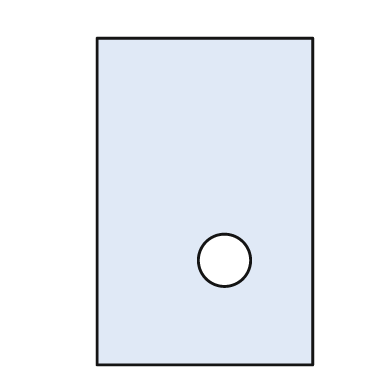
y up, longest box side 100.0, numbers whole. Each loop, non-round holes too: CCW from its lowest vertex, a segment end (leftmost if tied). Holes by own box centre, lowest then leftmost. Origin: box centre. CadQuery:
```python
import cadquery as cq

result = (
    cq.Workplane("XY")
    .moveTo(-33.0, -50.0)
    .lineTo(33.0, -50.0)
    .lineTo(33.0, 50.0)
    .lineTo(-33.0, 50.0)
    .close()
    .moveTo(6.0, -18.0)
    .circle(8.0)
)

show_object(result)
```